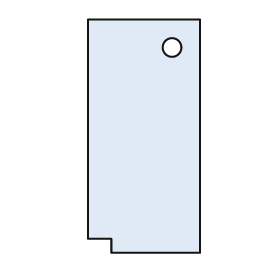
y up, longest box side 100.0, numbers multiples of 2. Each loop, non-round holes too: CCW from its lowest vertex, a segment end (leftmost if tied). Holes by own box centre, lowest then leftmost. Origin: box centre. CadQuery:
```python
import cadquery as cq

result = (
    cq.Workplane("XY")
    .moveTo(-14.0, -50.0)
    .lineTo(24.0, -50.0)
    .lineTo(24.0, 50.0)
    .lineTo(-24.0, 50.0)
    .lineTo(-24.0, -44.0)
    .lineTo(-14.0, -44.0)
    .close()
    .moveTo(12.0, 38.0)
    .circle(4.0)
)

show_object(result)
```